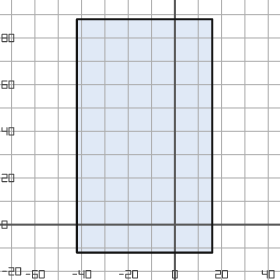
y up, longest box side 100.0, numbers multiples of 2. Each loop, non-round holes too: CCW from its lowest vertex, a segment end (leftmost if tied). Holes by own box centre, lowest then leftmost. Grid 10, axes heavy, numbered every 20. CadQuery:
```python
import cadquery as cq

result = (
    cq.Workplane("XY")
    .moveTo(-42.0, -12.0)
    .lineTo(16.0, -12.0)
    .lineTo(16.0, 88.0)
    .lineTo(-42.0, 88.0)
    .close()
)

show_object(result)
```